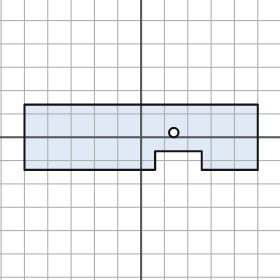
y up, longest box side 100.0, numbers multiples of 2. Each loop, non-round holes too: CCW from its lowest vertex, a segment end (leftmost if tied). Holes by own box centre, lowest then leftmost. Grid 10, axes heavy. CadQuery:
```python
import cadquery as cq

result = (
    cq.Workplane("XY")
    .moveTo(-50.0, -14.0)
    .lineTo(6.0, -14.0)
    .lineTo(6.0, -6.0)
    .lineTo(26.0, -6.0)
    .lineTo(26.0, -14.0)
    .lineTo(50.0, -14.0)
    .lineTo(50.0, 14.0)
    .lineTo(-50.0, 14.0)
    .close()
    .moveTo(14.0, 2.0)
    .circle(2.0)
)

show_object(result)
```